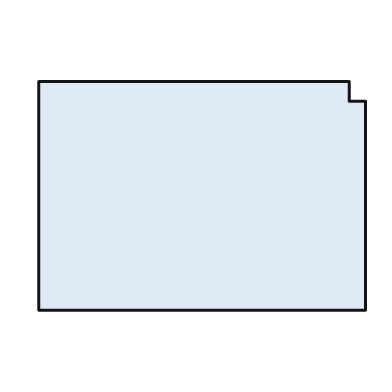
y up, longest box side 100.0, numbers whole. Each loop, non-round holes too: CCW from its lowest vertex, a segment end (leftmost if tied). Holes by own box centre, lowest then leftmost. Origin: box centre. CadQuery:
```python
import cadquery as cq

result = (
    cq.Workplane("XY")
    .moveTo(-50.0, -35.0)
    .lineTo(50.0, -35.0)
    .lineTo(50.0, 29.0)
    .lineTo(45.0, 29.0)
    .lineTo(45.0, 35.0)
    .lineTo(-50.0, 35.0)
    .close()
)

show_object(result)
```